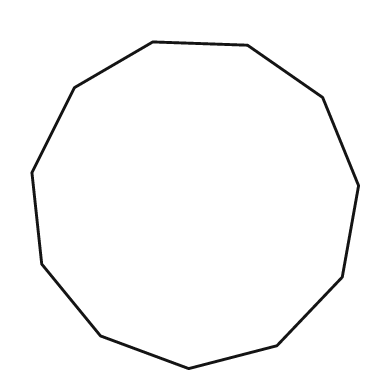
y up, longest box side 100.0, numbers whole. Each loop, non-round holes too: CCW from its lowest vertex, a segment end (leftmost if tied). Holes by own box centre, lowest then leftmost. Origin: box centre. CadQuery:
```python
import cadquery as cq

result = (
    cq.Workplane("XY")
    .moveTo(-2.0, -50.0)
    .lineTo(25.0, -43.0)
    .lineTo(45.0, -22.0)
    .lineTo(50.0, 6.0)
    .lineTo(39.0, 33.0)
    .lineTo(16.0, 49.0)
    .lineTo(-13.0, 50.0)
    .lineTo(-37.0, 36.0)
    .lineTo(-50.0, 10.0)
    .lineTo(-47.0, -18.0)
    .lineTo(-29.0, -40.0)
    .close()
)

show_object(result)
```